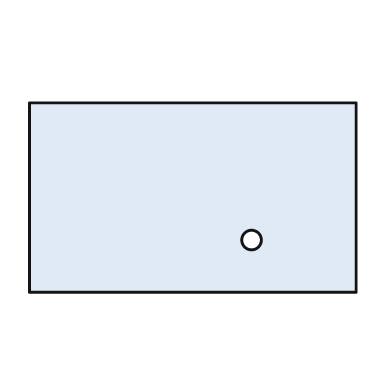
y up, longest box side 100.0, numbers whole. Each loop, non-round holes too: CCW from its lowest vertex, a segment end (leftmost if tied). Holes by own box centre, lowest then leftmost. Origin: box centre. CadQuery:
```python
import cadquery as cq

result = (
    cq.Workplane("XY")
    .moveTo(-50.0, -29.0)
    .lineTo(50.0, -29.0)
    .lineTo(50.0, 29.0)
    .lineTo(-50.0, 29.0)
    .close()
    .moveTo(18.0, -13.0)
    .circle(3.0)
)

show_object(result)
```